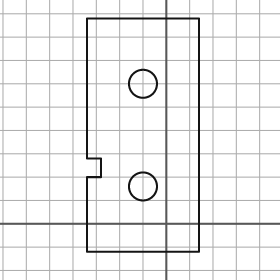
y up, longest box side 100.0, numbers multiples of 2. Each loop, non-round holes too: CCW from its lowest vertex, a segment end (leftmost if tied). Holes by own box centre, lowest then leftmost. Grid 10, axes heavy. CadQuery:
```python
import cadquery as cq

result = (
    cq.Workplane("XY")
    .moveTo(-34.0, -12.0)
    .lineTo(14.0, -12.0)
    .lineTo(14.0, 88.0)
    .lineTo(-34.0, 88.0)
    .lineTo(-34.0, 28.0)
    .lineTo(-28.0, 28.0)
    .lineTo(-28.0, 20.0)
    .lineTo(-34.0, 20.0)
    .close()
    .moveTo(-10.0, 16.0)
    .circle(6.0)
    .moveTo(-10.0, 60.0)
    .circle(6.0)
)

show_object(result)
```